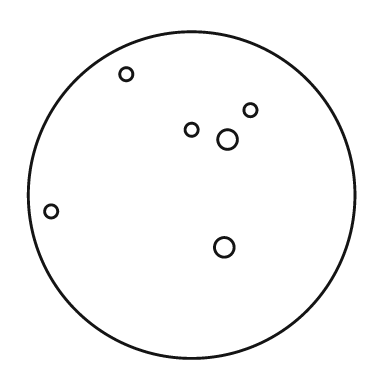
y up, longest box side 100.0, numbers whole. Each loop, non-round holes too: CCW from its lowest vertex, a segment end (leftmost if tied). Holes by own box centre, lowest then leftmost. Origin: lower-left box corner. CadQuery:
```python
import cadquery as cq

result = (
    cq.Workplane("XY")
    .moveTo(50.0, 50.0)
    .circle(50.0)
    .moveTo(60.0, 34.0)
    .circle(3.0)
    .moveTo(7.0, 45.0)
    .circle(2.0)
    .moveTo(61.0, 67.0)
    .circle(3.0)
    .moveTo(50.0, 70.0)
    .circle(2.0)
    .moveTo(68.0, 76.0)
    .circle(2.0)
    .moveTo(30.0, 87.0)
    .circle(2.0)
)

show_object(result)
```